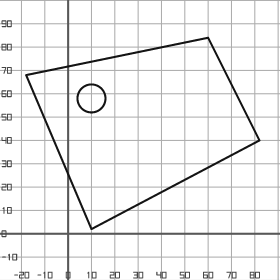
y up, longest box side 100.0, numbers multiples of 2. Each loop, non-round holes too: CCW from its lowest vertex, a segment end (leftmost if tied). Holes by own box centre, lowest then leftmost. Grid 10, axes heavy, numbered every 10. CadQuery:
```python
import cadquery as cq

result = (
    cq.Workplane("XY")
    .moveTo(10.0, 2.0)
    .lineTo(82.0, 40.0)
    .lineTo(60.0, 84.0)
    .lineTo(-18.0, 68.0)
    .close()
    .moveTo(10.0, 58.0)
    .circle(6.0)
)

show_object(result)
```